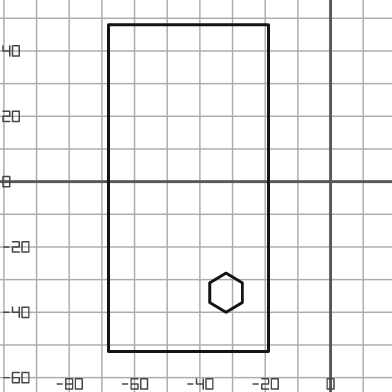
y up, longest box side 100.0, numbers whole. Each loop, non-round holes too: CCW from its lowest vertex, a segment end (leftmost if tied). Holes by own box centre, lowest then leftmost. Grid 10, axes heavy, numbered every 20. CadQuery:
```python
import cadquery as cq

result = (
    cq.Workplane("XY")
    .moveTo(-68.0, -52.0)
    .lineTo(-19.0, -52.0)
    .lineTo(-19.0, 48.0)
    .lineTo(-68.0, 48.0)
    .close()
    .moveTo(-32.0, -40.0)
    .lineTo(-27.0, -37.0)
    .lineTo(-27.0, -31.0)
    .lineTo(-32.0, -28.0)
    .lineTo(-37.0, -31.0)
    .lineTo(-37.0, -37.0)
    .close()
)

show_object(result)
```